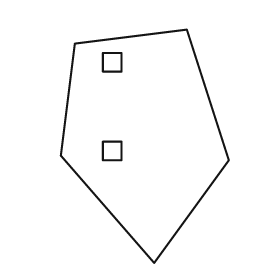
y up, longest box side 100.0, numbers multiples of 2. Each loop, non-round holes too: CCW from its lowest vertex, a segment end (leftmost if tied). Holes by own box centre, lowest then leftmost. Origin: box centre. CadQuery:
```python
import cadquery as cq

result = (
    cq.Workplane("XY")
    .moveTo(4.0, -50.0)
    .lineTo(36.0, -6.0)
    .lineTo(18.0, 50.0)
    .lineTo(-30.0, 44.0)
    .lineTo(-36.0, -4.0)
    .close()
    .moveTo(-18.0, -6.0)
    .lineTo(-10.0, -6.0)
    .lineTo(-10.0, 2.0)
    .lineTo(-18.0, 2.0)
    .close()
    .moveTo(-18.0, 32.0)
    .lineTo(-10.0, 32.0)
    .lineTo(-10.0, 40.0)
    .lineTo(-18.0, 40.0)
    .close()
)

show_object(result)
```